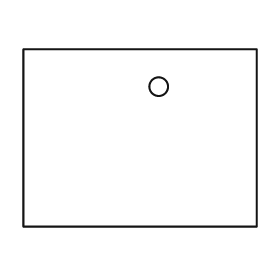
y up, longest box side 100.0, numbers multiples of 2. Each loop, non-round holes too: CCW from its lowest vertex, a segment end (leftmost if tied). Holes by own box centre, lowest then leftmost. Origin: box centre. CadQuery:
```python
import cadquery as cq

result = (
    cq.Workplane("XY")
    .moveTo(-50.0, -38.0)
    .lineTo(50.0, -38.0)
    .lineTo(50.0, 38.0)
    .lineTo(-50.0, 38.0)
    .close()
    .moveTo(8.0, 22.0)
    .circle(4.0)
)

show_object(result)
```